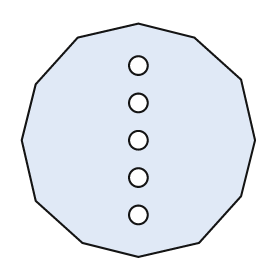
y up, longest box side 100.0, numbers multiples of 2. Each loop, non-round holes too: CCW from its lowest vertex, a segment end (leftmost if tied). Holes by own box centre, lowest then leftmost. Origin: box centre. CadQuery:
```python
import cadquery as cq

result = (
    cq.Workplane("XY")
    .moveTo(0.0, -50.0)
    .lineTo(26.0, -44.0)
    .lineTo(44.0, -24.0)
    .lineTo(50.0, 0.0)
    .lineTo(44.0, 26.0)
    .lineTo(24.0, 44.0)
    .lineTo(0.0, 50.0)
    .lineTo(-26.0, 44.0)
    .lineTo(-44.0, 24.0)
    .lineTo(-50.0, 0.0)
    .lineTo(-44.0, -26.0)
    .lineTo(-24.0, -44.0)
    .close()
    .moveTo(0.0, -32.0)
    .circle(4.0)
    .moveTo(0.0, -16.0)
    .circle(4.0)
    .moveTo(0.0, 0.0)
    .circle(4.0)
    .moveTo(0.0, 16.0)
    .circle(4.0)
    .moveTo(0.0, 32.0)
    .circle(4.0)
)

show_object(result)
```